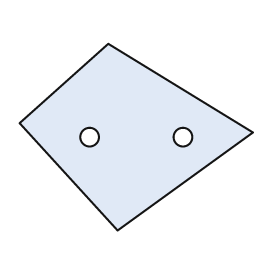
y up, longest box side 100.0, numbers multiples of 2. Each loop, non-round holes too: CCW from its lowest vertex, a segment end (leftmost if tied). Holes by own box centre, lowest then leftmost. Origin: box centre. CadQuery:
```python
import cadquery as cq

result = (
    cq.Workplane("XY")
    .moveTo(-8.0, -40.0)
    .lineTo(50.0, 2.0)
    .lineTo(-12.0, 40.0)
    .lineTo(-50.0, 6.0)
    .close()
    .moveTo(-20.0, 0.0)
    .circle(4.0)
    .moveTo(20.0, 0.0)
    .circle(4.0)
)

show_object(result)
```